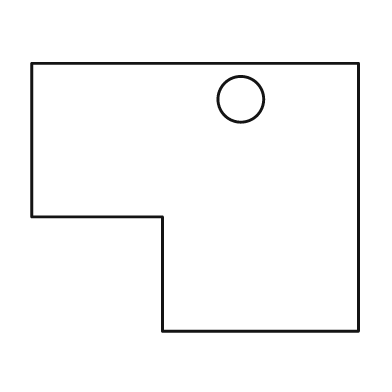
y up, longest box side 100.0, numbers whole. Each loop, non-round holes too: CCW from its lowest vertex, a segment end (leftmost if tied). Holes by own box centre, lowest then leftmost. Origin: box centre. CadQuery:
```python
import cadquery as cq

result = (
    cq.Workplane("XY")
    .moveTo(-10.0, -41.0)
    .lineTo(50.0, -41.0)
    .lineTo(50.0, 41.0)
    .lineTo(-50.0, 41.0)
    .lineTo(-50.0, -6.0)
    .lineTo(-10.0, -6.0)
    .close()
    .moveTo(14.0, 30.0)
    .circle(7.0)
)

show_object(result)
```